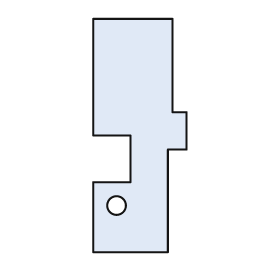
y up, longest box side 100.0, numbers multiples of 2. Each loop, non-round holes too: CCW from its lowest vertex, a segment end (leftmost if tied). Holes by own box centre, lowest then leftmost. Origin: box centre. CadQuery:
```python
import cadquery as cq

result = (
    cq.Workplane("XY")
    .moveTo(-20.0, -50.0)
    .lineTo(12.0, -50.0)
    .lineTo(12.0, -6.0)
    .lineTo(20.0, -6.0)
    .lineTo(20.0, 10.0)
    .lineTo(14.0, 10.0)
    .lineTo(14.0, 50.0)
    .lineTo(-20.0, 50.0)
    .lineTo(-20.0, 0.0)
    .lineTo(-4.0, 0.0)
    .lineTo(-4.0, -20.0)
    .lineTo(-20.0, -20.0)
    .close()
    .moveTo(-10.0, -30.0)
    .circle(4.0)
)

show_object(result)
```